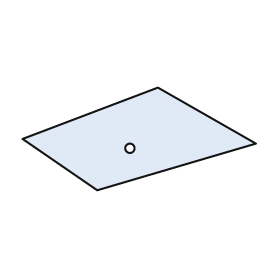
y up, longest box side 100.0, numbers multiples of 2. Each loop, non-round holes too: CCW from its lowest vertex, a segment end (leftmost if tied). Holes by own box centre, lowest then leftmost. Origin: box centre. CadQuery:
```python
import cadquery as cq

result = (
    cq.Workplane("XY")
    .moveTo(-18.0, -22.0)
    .lineTo(50.0, -2.0)
    .lineTo(8.0, 22.0)
    .lineTo(-50.0, 0.0)
    .close()
    .moveTo(-4.0, -4.0)
    .circle(2.0)
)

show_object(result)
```